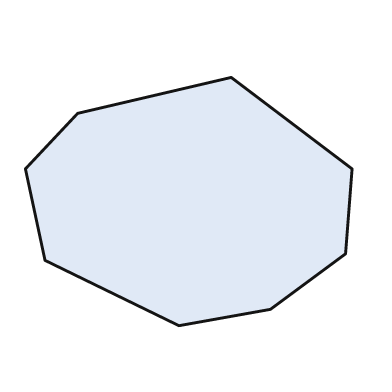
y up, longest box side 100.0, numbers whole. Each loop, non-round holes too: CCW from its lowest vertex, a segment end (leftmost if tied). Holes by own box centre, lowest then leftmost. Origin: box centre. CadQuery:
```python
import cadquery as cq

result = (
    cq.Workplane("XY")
    .moveTo(-3.0, -38.0)
    .lineTo(25.0, -33.0)
    .lineTo(48.0, -16.0)
    .lineTo(50.0, 10.0)
    .lineTo(13.0, 38.0)
    .lineTo(-34.0, 27.0)
    .lineTo(-50.0, 10.0)
    .lineTo(-44.0, -18.0)
    .close()
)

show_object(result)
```